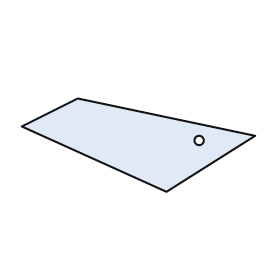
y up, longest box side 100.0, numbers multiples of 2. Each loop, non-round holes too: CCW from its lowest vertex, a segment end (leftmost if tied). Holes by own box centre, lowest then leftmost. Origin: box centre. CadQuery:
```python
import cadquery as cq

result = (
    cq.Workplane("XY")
    .moveTo(12.0, -20.0)
    .lineTo(50.0, 4.0)
    .lineTo(-26.0, 20.0)
    .lineTo(-50.0, 8.0)
    .close()
    .moveTo(26.0, 2.0)
    .circle(2.0)
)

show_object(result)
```